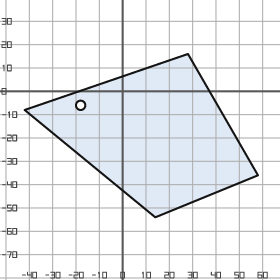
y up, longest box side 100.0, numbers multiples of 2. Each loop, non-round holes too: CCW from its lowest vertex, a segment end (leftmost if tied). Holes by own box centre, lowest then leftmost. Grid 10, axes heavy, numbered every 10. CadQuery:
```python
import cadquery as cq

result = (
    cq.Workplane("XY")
    .moveTo(14.0, -54.0)
    .lineTo(58.0, -36.0)
    .lineTo(28.0, 16.0)
    .lineTo(-42.0, -8.0)
    .close()
    .moveTo(-18.0, -6.0)
    .circle(2.0)
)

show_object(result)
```